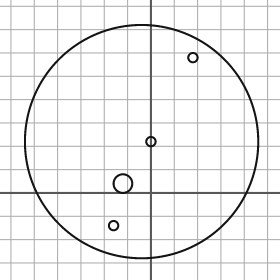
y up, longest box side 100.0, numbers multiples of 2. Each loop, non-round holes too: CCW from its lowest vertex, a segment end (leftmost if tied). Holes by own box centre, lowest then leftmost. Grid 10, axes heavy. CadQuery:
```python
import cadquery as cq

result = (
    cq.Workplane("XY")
    .moveTo(-4.0, 22.0)
    .circle(50.0)
    .moveTo(-16.0, -14.0)
    .circle(2.0)
    .moveTo(-12.0, 4.0)
    .circle(4.0)
    .moveTo(0.0, 22.0)
    .circle(2.0)
    .moveTo(18.0, 58.0)
    .circle(2.0)
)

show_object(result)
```